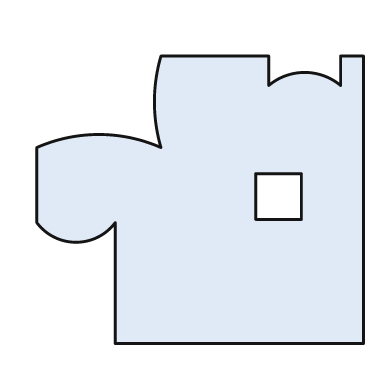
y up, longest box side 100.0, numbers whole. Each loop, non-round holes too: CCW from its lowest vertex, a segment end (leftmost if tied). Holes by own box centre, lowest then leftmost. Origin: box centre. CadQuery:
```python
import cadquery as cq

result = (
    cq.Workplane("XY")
    .moveTo(-26.0, -44.0)
    .lineTo(50.0, -44.0)
    .lineTo(50.0, 44.0)
    .lineTo(43.0, 44.0)
    .lineTo(43.0, 35.0)
    .threePointArc((32.0, 39.0), (21.0, 35.0))
    .lineTo(21.0, 44.0)
    .lineTo(-12.0, 44.0)
    .threePointArc((-14.0, 30.0), (-12.0, 16.0))
    .threePointArc((-31.0, 20.0), (-50.0, 16.0))
    .lineTo(-50.0, -7.0)
    .threePointArc((-38.0, -13.0), (-26.0, -7.0))
    .close()
    .moveTo(17.0, -6.0)
    .lineTo(31.0, -6.0)
    .lineTo(31.0, 8.0)
    .lineTo(17.0, 8.0)
    .close()
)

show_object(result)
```